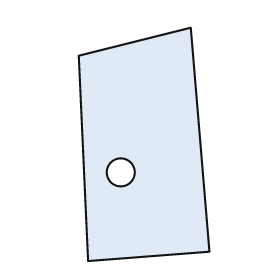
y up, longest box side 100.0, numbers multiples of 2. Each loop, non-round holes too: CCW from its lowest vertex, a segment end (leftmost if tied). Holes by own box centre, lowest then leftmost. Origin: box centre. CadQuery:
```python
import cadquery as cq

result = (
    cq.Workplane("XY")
    .moveTo(-24.0, -50.0)
    .lineTo(28.0, -46.0)
    .lineTo(20.0, 50.0)
    .lineTo(-28.0, 38.0)
    .close()
    .moveTo(-10.0, -12.0)
    .circle(6.0)
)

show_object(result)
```